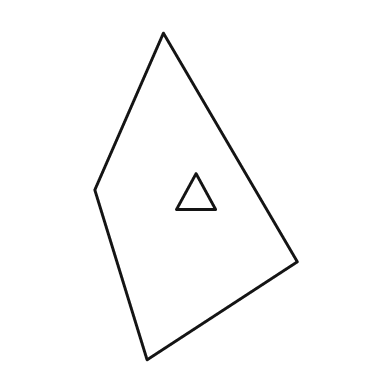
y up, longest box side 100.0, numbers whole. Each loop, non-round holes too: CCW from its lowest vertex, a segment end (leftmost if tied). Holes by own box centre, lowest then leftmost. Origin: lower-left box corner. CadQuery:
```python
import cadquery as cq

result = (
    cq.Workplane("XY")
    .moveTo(16.0, 0.0)
    .lineTo(62.0, 30.0)
    .lineTo(21.0, 100.0)
    .lineTo(0.0, 52.0)
    .close()
    .moveTo(25.0, 46.0)
    .lineTo(37.0, 46.0)
    .lineTo(31.0, 57.0)
    .close()
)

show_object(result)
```